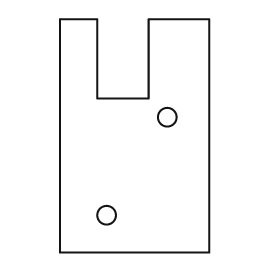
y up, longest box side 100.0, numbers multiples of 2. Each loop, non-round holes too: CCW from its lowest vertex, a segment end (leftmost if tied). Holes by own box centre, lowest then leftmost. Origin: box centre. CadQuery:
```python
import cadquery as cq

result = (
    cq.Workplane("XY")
    .moveTo(-32.0, -50.0)
    .lineTo(32.0, -50.0)
    .lineTo(32.0, 50.0)
    .lineTo(6.0, 50.0)
    .lineTo(6.0, 16.0)
    .lineTo(-16.0, 16.0)
    .lineTo(-16.0, 50.0)
    .lineTo(-32.0, 50.0)
    .close()
    .moveTo(-12.0, -34.0)
    .circle(4.0)
    .moveTo(14.0, 8.0)
    .circle(4.0)
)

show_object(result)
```